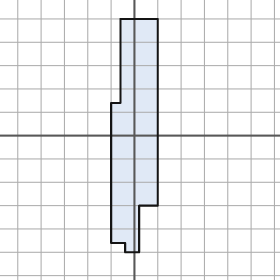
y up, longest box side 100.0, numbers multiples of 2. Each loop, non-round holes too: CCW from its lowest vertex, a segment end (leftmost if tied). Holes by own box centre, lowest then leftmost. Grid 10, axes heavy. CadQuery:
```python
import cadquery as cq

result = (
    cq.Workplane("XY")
    .moveTo(-4.0, -50.0)
    .lineTo(2.0, -50.0)
    .lineTo(2.0, -30.0)
    .lineTo(10.0, -30.0)
    .lineTo(10.0, 50.0)
    .lineTo(-6.0, 50.0)
    .lineTo(-6.0, 14.0)
    .lineTo(-10.0, 14.0)
    .lineTo(-10.0, -46.0)
    .lineTo(-4.0, -46.0)
    .close()
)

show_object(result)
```